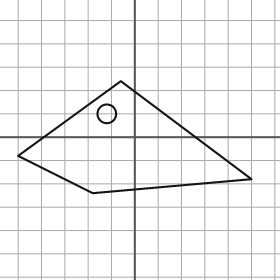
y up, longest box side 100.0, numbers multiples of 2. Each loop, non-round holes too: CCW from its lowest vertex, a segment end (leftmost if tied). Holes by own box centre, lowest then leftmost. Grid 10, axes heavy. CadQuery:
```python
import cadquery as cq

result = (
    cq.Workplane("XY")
    .moveTo(-18.0, -24.0)
    .lineTo(50.0, -18.0)
    .lineTo(-6.0, 24.0)
    .lineTo(-50.0, -8.0)
    .close()
    .moveTo(-12.0, 10.0)
    .circle(4.0)
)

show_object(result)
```